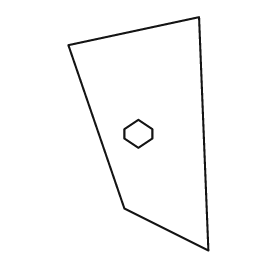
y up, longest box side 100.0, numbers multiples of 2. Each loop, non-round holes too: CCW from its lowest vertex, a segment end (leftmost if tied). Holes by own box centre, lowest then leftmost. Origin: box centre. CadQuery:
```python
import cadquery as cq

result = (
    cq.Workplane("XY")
    .moveTo(30.0, -50.0)
    .lineTo(26.0, 50.0)
    .lineTo(-30.0, 38.0)
    .lineTo(-6.0, -32.0)
    .close()
    .moveTo(0.0, -6.0)
    .lineTo(6.0, -2.0)
    .lineTo(6.0, 2.0)
    .lineTo(0.0, 6.0)
    .lineTo(-6.0, 2.0)
    .lineTo(-6.0, -2.0)
    .close()
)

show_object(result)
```